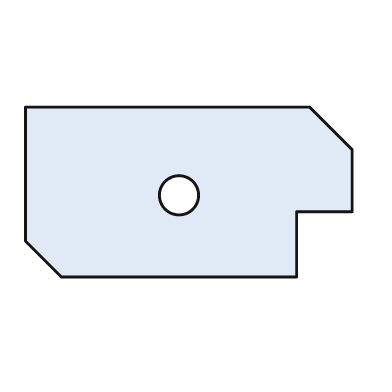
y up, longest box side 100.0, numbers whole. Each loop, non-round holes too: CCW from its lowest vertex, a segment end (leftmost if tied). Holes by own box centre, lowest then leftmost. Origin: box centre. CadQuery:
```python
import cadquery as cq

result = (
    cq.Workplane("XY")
    .moveTo(-39.0, -26.0)
    .lineTo(33.0, -26.0)
    .lineTo(33.0, -6.0)
    .lineTo(50.0, -6.0)
    .lineTo(50.0, 13.0)
    .lineTo(37.0, 26.0)
    .lineTo(-50.0, 26.0)
    .lineTo(-50.0, -15.0)
    .close()
    .moveTo(-3.0, -1.0)
    .circle(6.0)
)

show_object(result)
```